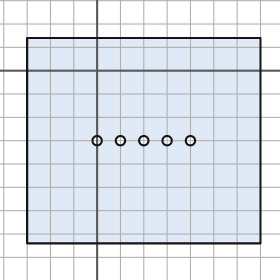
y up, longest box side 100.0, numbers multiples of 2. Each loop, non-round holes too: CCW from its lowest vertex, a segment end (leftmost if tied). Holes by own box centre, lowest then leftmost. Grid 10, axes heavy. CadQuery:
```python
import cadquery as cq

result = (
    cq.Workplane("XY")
    .moveTo(-30.0, -74.0)
    .lineTo(70.0, -74.0)
    .lineTo(70.0, 14.0)
    .lineTo(-30.0, 14.0)
    .close()
    .moveTo(0.0, -30.0)
    .circle(2.0)
    .moveTo(10.0, -30.0)
    .circle(2.0)
    .moveTo(20.0, -30.0)
    .circle(2.0)
    .moveTo(30.0, -30.0)
    .circle(2.0)
    .moveTo(40.0, -30.0)
    .circle(2.0)
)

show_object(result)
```